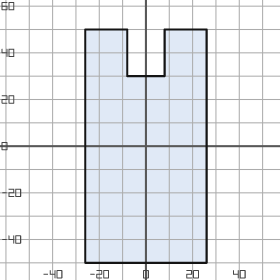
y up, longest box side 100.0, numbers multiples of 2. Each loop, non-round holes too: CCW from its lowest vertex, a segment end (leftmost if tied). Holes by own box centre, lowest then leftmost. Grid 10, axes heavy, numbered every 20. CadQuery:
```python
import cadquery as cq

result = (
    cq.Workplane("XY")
    .moveTo(-26.0, -50.0)
    .lineTo(26.0, -50.0)
    .lineTo(26.0, 50.0)
    .lineTo(8.0, 50.0)
    .lineTo(8.0, 30.0)
    .lineTo(-8.0, 30.0)
    .lineTo(-8.0, 50.0)
    .lineTo(-26.0, 50.0)
    .close()
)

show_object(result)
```